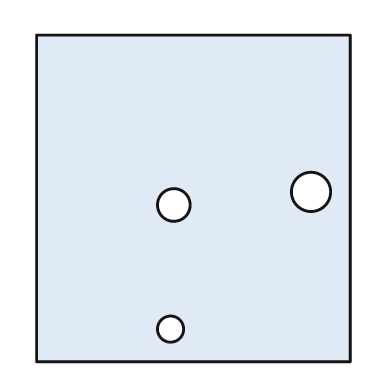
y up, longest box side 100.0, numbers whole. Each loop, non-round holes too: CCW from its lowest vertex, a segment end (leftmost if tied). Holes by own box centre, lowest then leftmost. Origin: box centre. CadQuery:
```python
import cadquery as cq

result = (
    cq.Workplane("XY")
    .moveTo(-48.0, -50.0)
    .lineTo(48.0, -50.0)
    .lineTo(48.0, 50.0)
    .lineTo(-48.0, 50.0)
    .close()
    .moveTo(-7.0, -40.0)
    .circle(4.0)
    .moveTo(-6.0, -2.0)
    .circle(5.0)
    .moveTo(36.0, 2.0)
    .circle(6.0)
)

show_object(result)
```